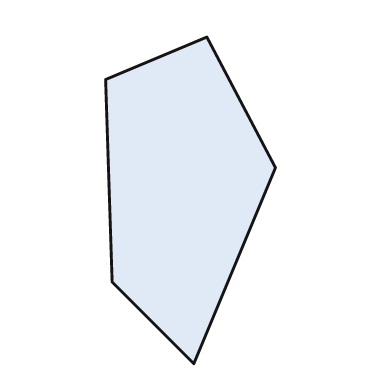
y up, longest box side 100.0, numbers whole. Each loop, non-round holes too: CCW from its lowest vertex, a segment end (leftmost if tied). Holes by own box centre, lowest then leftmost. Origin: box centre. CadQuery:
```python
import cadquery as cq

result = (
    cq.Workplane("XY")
    .moveTo(1.0, -50.0)
    .lineTo(26.0, 10.0)
    .lineTo(5.0, 50.0)
    .lineTo(-26.0, 37.0)
    .lineTo(-24.0, -25.0)
    .close()
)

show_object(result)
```